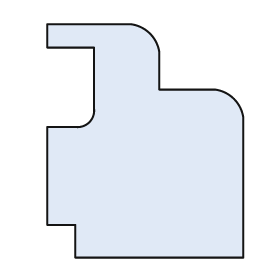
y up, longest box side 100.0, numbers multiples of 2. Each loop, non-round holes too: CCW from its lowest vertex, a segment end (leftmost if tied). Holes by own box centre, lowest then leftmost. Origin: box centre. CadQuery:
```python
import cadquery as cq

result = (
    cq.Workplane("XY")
    .moveTo(-30.0, -50.0)
    .lineTo(42.0, -50.0)
    .lineTo(42.0, 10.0)
    .threePointArc((38.0, 18.0), (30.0, 22.0))
    .lineTo(6.0, 22.0)
    .lineTo(6.0, 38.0)
    .threePointArc((2.0, 46.0), (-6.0, 50.0))
    .lineTo(-42.0, 50.0)
    .lineTo(-42.0, 40.0)
    .lineTo(-22.0, 40.0)
    .lineTo(-22.0, 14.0)
    .threePointArc((-24.0, 8.0), (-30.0, 6.0))
    .lineTo(-42.0, 6.0)
    .lineTo(-42.0, -36.0)
    .lineTo(-30.0, -36.0)
    .close()
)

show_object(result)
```